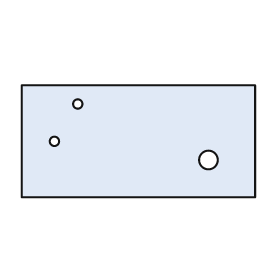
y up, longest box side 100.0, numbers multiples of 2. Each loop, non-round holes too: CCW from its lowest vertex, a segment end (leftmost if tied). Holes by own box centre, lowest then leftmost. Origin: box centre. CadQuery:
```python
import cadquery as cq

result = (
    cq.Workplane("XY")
    .moveTo(-50.0, -24.0)
    .lineTo(50.0, -24.0)
    .lineTo(50.0, 24.0)
    .lineTo(-50.0, 24.0)
    .close()
    .moveTo(30.0, -8.0)
    .circle(4.0)
    .moveTo(-36.0, 0.0)
    .circle(2.0)
    .moveTo(-26.0, 16.0)
    .circle(2.0)
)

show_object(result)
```